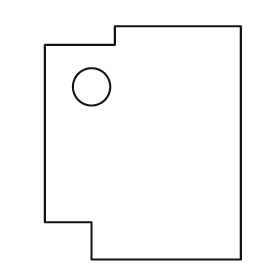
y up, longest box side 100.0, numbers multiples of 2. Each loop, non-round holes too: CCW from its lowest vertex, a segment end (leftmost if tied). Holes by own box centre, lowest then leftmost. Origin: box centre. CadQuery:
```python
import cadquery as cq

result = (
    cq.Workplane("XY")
    .moveTo(-22.0, -50.0)
    .lineTo(42.0, -50.0)
    .lineTo(42.0, 50.0)
    .lineTo(-12.0, 50.0)
    .lineTo(-12.0, 42.0)
    .lineTo(-42.0, 42.0)
    .lineTo(-42.0, -34.0)
    .lineTo(-22.0, -34.0)
    .close()
    .moveTo(-22.0, 24.0)
    .circle(8.0)
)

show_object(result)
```